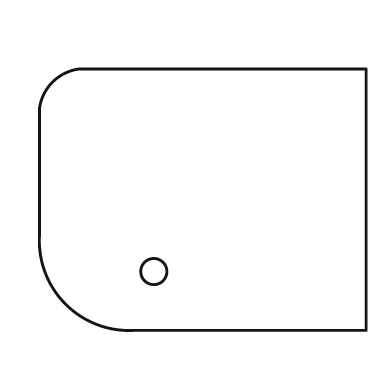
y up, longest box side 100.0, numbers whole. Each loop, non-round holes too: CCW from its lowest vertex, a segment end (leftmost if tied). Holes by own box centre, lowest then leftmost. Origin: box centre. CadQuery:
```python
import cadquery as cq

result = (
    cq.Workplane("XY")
    .moveTo(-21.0, -40.0)
    .lineTo(50.0, -40.0)
    .lineTo(50.0, 40.0)
    .lineTo(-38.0, 40.0)
    .threePointArc((-46.0, 36.0), (-50.0, 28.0))
    .lineTo(-50.0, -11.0)
    .threePointArc((-42.0, -32.0), (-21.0, -40.0))
    .close()
    .moveTo(-15.0, -22.0)
    .circle(4.0)
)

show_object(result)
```